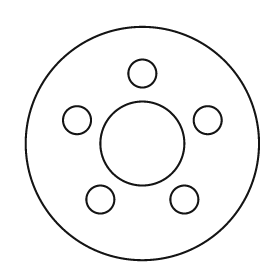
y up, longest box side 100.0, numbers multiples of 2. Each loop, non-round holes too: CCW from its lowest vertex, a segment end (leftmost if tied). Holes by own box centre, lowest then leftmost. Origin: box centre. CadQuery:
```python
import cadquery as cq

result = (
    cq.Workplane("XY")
    .moveTo(0.0, 0.0)
    .circle(50.0)
    .moveTo(-18.0, -24.0)
    .circle(6.0)
    .moveTo(18.0, -24.0)
    .circle(6.0)
    .moveTo(0.0, 0.0)
    .circle(18.0)
    .moveTo(-28.0, 10.0)
    .circle(6.0)
    .moveTo(28.0, 10.0)
    .circle(6.0)
    .moveTo(0.0, 30.0)
    .circle(6.0)
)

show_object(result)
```